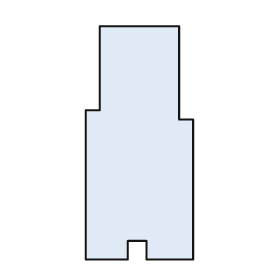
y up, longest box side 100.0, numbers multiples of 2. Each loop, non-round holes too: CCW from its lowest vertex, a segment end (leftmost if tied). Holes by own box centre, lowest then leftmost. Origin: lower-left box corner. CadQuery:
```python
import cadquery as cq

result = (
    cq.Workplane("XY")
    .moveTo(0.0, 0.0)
    .lineTo(18.0, 0.0)
    .lineTo(18.0, 8.0)
    .lineTo(26.0, 8.0)
    .lineTo(26.0, 0.0)
    .lineTo(46.0, 0.0)
    .lineTo(46.0, 60.0)
    .lineTo(40.0, 60.0)
    .lineTo(40.0, 100.0)
    .lineTo(6.0, 100.0)
    .lineTo(6.0, 64.0)
    .lineTo(0.0, 64.0)
    .close()
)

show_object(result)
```